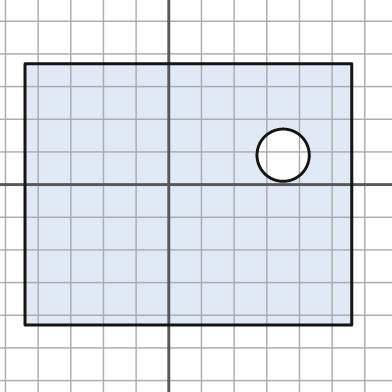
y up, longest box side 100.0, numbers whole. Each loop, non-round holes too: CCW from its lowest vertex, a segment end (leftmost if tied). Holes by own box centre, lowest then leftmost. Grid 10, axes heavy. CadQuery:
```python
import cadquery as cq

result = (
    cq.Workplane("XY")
    .moveTo(-44.0, -43.0)
    .lineTo(56.0, -43.0)
    .lineTo(56.0, 37.0)
    .lineTo(-44.0, 37.0)
    .close()
    .moveTo(35.0, 9.0)
    .circle(8.0)
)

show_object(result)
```